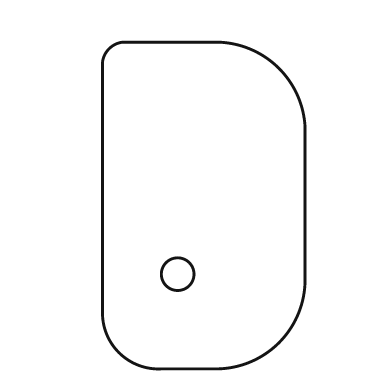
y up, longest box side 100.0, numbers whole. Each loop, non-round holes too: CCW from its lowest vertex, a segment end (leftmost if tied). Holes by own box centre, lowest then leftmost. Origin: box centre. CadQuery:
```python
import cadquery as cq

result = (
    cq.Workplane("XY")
    .moveTo(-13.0, -50.0)
    .lineTo(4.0, -50.0)
    .threePointArc((23.0, -42.0), (31.0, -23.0))
    .lineTo(31.0, 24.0)
    .threePointArc((23.0, 42.0), (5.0, 50.0))
    .lineTo(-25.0, 50.0)
    .threePointArc((-29.0, 48.0), (-31.0, 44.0))
    .lineTo(-31.0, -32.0)
    .threePointArc((-26.0, -45.0), (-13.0, -50.0))
    .close()
    .moveTo(-8.0, -21.0)
    .circle(5.0)
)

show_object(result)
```